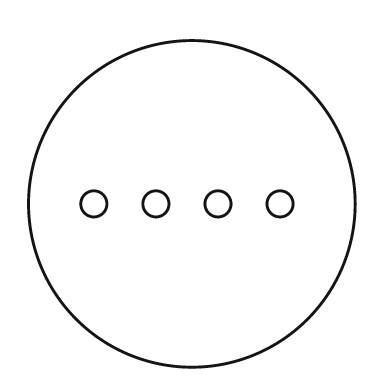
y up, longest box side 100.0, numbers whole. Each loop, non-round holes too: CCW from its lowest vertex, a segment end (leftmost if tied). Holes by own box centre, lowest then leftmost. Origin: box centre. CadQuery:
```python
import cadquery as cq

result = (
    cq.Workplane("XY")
    .moveTo(0.0, 0.0)
    .circle(50.0)
    .moveTo(-30.0, 0.0)
    .circle(4.0)
    .moveTo(-11.0, 0.0)
    .circle(4.0)
    .moveTo(8.0, 0.0)
    .circle(4.0)
    .moveTo(27.0, 0.0)
    .circle(4.0)
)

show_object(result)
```